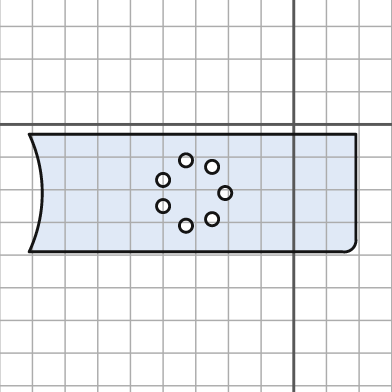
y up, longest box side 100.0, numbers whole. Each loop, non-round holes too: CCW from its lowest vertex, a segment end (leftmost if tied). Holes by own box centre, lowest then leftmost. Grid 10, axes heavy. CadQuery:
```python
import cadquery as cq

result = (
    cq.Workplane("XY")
    .moveTo(-81.0, -39.0)
    .lineTo(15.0, -39.0)
    .threePointArc((18.0, -38.0), (19.0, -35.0))
    .lineTo(19.0, -3.0)
    .lineTo(-81.0, -3.0)
    .threePointArc((-77.0, -21.0), (-81.0, -39.0))
    .close()
    .moveTo(-33.0, -31.0)
    .circle(2.0)
    .moveTo(-25.0, -29.0)
    .circle(2.0)
    .moveTo(-40.0, -25.0)
    .circle(2.0)
    .moveTo(-21.0, -21.0)
    .circle(2.0)
    .moveTo(-40.0, -17.0)
    .circle(2.0)
    .moveTo(-25.0, -13.0)
    .circle(2.0)
    .moveTo(-33.0, -11.0)
    .circle(2.0)
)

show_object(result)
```